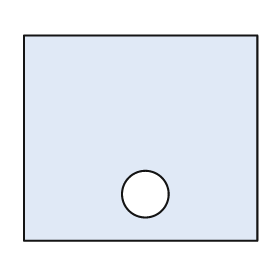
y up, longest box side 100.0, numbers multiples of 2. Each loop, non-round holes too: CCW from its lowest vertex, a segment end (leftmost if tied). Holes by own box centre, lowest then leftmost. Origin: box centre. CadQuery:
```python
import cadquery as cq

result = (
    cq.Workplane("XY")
    .moveTo(-50.0, -44.0)
    .lineTo(50.0, -44.0)
    .lineTo(50.0, 44.0)
    .lineTo(-50.0, 44.0)
    .close()
    .moveTo(2.0, -24.0)
    .circle(10.0)
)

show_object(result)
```